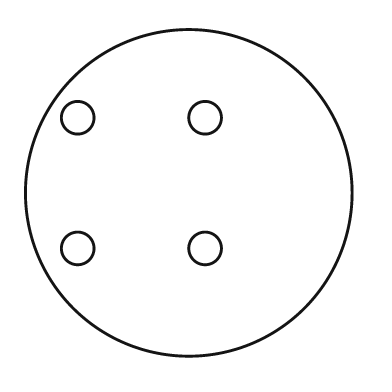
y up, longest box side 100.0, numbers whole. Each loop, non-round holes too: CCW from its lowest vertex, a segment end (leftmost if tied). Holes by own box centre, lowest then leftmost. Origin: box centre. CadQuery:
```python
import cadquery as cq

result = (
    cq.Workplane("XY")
    .moveTo(0.0, 0.0)
    .circle(50.0)
    .moveTo(-34.0, -17.0)
    .circle(5.0)
    .moveTo(5.0, -17.0)
    .circle(5.0)
    .moveTo(-34.0, 23.0)
    .circle(5.0)
    .moveTo(5.0, 23.0)
    .circle(5.0)
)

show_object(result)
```